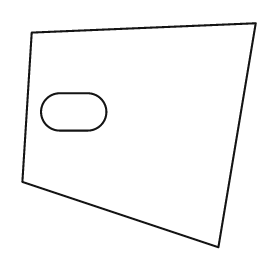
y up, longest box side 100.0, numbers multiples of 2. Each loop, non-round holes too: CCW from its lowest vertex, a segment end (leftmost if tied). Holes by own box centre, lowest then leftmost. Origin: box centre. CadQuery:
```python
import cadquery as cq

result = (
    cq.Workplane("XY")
    .moveTo(34.0, -48.0)
    .lineTo(50.0, 48.0)
    .lineTo(-46.0, 44.0)
    .lineTo(-50.0, -20.0)
    .close()
    .moveTo(-34.0, 2.0)
    .lineTo(-22.0, 2.0)
    .threePointArc((-14.0, 10.0), (-22.0, 18.0))
    .lineTo(-34.0, 18.0)
    .threePointArc((-42.0, 10.0), (-34.0, 2.0))
    .close()
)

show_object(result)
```